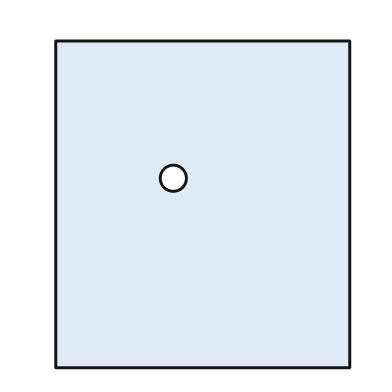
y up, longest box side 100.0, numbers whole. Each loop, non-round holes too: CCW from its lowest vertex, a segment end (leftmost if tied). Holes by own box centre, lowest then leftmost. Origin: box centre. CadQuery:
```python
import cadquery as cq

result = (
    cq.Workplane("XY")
    .moveTo(-45.0, -50.0)
    .lineTo(45.0, -50.0)
    .lineTo(45.0, 50.0)
    .lineTo(-45.0, 50.0)
    .close()
    .moveTo(-9.0, 8.0)
    .circle(4.0)
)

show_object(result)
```